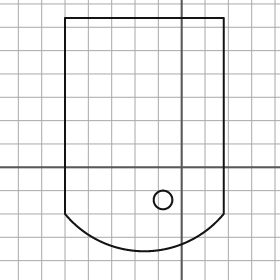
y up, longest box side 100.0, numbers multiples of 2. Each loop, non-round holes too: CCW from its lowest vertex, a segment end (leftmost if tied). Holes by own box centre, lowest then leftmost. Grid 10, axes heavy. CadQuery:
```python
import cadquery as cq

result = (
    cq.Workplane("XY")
    .moveTo(-50.0, -20.0)
    .threePointArc((-16.0, -36.0), (18.0, -20.0))
    .lineTo(18.0, 64.0)
    .lineTo(-50.0, 64.0)
    .close()
    .moveTo(-8.0, -14.0)
    .circle(4.0)
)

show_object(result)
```